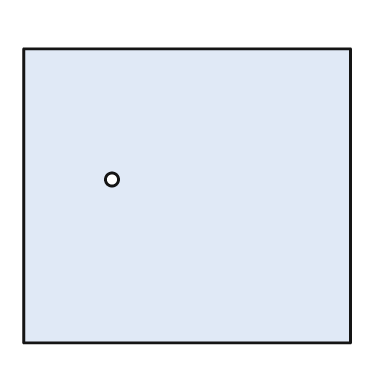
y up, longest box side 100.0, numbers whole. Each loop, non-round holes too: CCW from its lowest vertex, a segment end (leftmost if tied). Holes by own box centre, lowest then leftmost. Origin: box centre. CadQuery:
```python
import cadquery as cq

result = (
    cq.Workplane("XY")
    .moveTo(-50.0, -45.0)
    .lineTo(50.0, -45.0)
    .lineTo(50.0, 45.0)
    .lineTo(-50.0, 45.0)
    .close()
    .moveTo(-23.0, 5.0)
    .circle(2.0)
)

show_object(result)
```